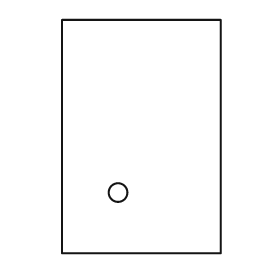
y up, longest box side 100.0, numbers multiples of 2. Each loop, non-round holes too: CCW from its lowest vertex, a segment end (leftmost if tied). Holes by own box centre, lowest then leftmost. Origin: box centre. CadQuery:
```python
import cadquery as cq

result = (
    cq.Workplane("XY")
    .moveTo(-34.0, -50.0)
    .lineTo(34.0, -50.0)
    .lineTo(34.0, 50.0)
    .lineTo(-34.0, 50.0)
    .close()
    .moveTo(-10.0, -24.0)
    .circle(4.0)
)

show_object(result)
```